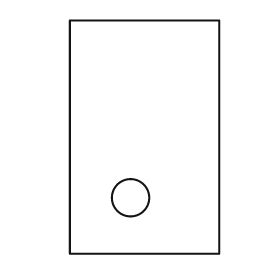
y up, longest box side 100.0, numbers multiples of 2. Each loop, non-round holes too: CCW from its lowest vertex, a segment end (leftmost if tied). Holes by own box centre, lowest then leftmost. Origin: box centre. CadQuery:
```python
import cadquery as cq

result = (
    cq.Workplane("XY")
    .moveTo(-32.0, -50.0)
    .lineTo(32.0, -50.0)
    .lineTo(32.0, 50.0)
    .lineTo(-32.0, 50.0)
    .close()
    .moveTo(-6.0, -26.0)
    .circle(8.0)
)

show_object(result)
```